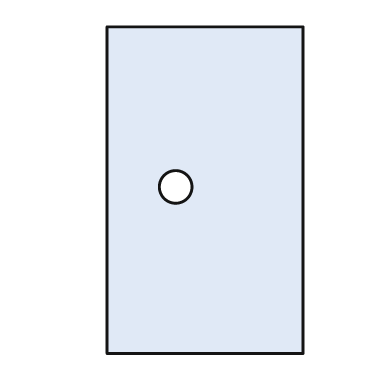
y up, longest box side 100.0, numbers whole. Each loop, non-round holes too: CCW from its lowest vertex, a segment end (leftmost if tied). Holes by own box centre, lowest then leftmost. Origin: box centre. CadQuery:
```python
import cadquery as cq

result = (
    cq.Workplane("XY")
    .moveTo(-30.0, -50.0)
    .lineTo(30.0, -50.0)
    .lineTo(30.0, 50.0)
    .lineTo(-30.0, 50.0)
    .close()
    .moveTo(-9.0, 1.0)
    .circle(5.0)
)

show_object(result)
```